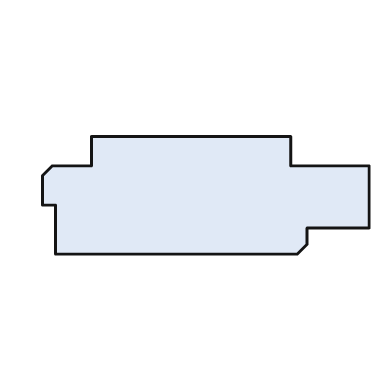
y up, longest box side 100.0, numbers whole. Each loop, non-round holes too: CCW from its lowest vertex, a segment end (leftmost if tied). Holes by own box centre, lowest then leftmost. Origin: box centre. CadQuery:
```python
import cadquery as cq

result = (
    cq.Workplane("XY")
    .moveTo(-46.0, -18.0)
    .lineTo(28.0, -18.0)
    .lineTo(31.0, -15.0)
    .lineTo(31.0, -10.0)
    .lineTo(50.0, -10.0)
    .lineTo(50.0, 9.0)
    .lineTo(26.0, 9.0)
    .lineTo(26.0, 18.0)
    .lineTo(-35.0, 18.0)
    .lineTo(-35.0, 9.0)
    .lineTo(-47.0, 9.0)
    .lineTo(-50.0, 6.0)
    .lineTo(-50.0, -3.0)
    .lineTo(-46.0, -3.0)
    .close()
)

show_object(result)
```